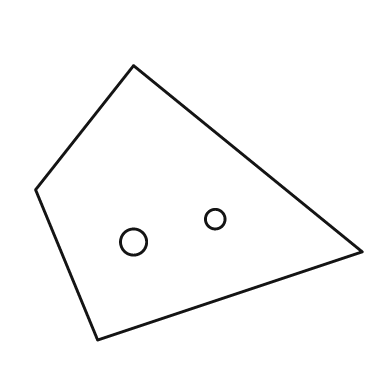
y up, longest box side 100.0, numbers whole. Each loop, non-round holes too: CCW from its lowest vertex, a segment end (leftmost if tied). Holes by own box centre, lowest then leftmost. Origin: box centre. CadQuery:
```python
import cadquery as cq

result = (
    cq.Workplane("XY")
    .moveTo(-31.0, -42.0)
    .lineTo(50.0, -15.0)
    .lineTo(-20.0, 42.0)
    .lineTo(-50.0, 4.0)
    .close()
    .moveTo(-20.0, -12.0)
    .circle(4.0)
    .moveTo(5.0, -5.0)
    .circle(3.0)
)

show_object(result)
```